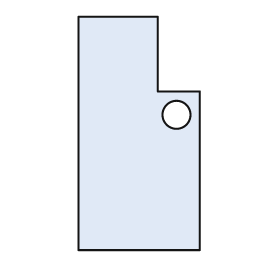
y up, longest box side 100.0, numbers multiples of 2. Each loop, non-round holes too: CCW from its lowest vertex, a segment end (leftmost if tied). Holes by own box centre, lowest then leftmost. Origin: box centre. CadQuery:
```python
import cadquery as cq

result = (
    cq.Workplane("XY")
    .moveTo(-26.0, -50.0)
    .lineTo(26.0, -50.0)
    .lineTo(26.0, 18.0)
    .lineTo(8.0, 18.0)
    .lineTo(8.0, 50.0)
    .lineTo(-26.0, 50.0)
    .close()
    .moveTo(16.0, 8.0)
    .circle(6.0)
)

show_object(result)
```